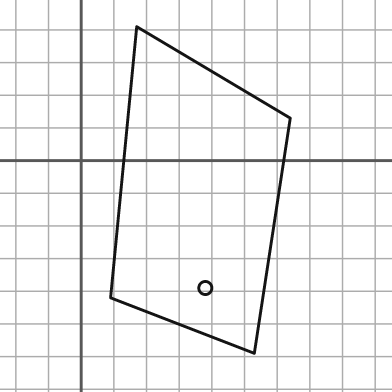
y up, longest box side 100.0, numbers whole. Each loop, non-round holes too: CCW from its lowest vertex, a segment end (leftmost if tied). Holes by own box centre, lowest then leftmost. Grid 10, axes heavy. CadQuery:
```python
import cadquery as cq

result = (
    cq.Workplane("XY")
    .moveTo(53.0, -59.0)
    .lineTo(64.0, 13.0)
    .lineTo(17.0, 41.0)
    .lineTo(9.0, -42.0)
    .close()
    .moveTo(38.0, -39.0)
    .circle(2.0)
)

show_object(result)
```